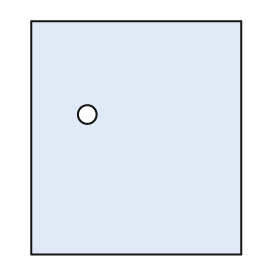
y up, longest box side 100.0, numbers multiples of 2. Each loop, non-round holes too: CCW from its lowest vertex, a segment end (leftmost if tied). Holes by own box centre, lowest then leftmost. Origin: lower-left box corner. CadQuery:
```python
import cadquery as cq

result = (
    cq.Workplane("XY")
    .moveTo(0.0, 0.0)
    .lineTo(90.0, 0.0)
    .lineTo(90.0, 100.0)
    .lineTo(0.0, 100.0)
    .close()
    .moveTo(24.0, 60.0)
    .circle(4.0)
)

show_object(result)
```